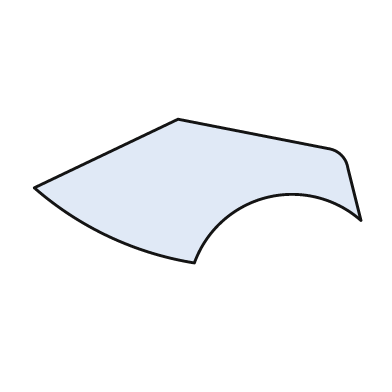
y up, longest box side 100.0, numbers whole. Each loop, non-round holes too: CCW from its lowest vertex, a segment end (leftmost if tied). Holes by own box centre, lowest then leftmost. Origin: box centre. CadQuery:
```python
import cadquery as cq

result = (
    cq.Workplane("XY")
    .moveTo(-1.0, -22.0)
    .threePointArc((21.0, -2.0), (50.0, -9.0))
    .lineTo(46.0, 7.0)
    .threePointArc((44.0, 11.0), (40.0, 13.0))
    .lineTo(-6.0, 22.0)
    .lineTo(-50.0, 1.0)
    .threePointArc((-27.0, -14.0), (-1.0, -22.0))
    .close()
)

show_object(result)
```